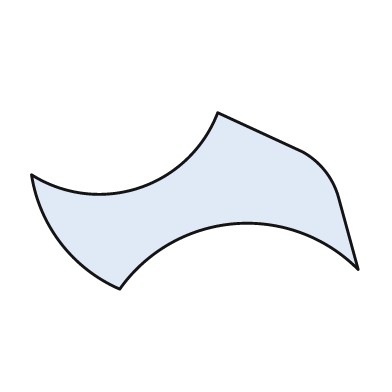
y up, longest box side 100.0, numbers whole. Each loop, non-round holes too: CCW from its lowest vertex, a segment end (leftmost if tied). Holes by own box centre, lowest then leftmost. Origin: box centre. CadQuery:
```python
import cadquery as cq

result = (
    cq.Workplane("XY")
    .moveTo(-23.0, -27.0)
    .threePointArc((12.0, -7.0), (50.0, -21.0))
    .lineTo(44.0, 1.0)
    .threePointArc((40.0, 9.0), (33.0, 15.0))
    .lineTo(7.0, 27.0)
    .threePointArc((-17.0, 4.0), (-50.0, 8.0))
    .threePointArc((-41.0, -13.0), (-23.0, -27.0))
    .close()
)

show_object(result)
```